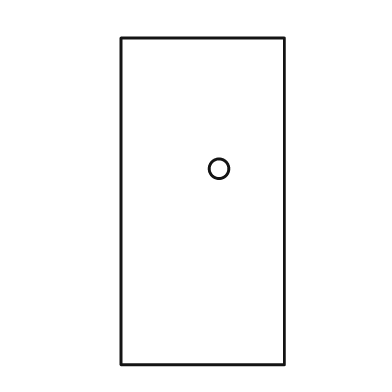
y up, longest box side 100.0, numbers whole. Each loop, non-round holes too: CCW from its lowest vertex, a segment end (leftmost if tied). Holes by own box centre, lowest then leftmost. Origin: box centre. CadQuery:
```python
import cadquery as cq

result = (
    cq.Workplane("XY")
    .moveTo(-25.0, -50.0)
    .lineTo(25.0, -50.0)
    .lineTo(25.0, 50.0)
    .lineTo(-25.0, 50.0)
    .close()
    .moveTo(5.0, 10.0)
    .circle(3.0)
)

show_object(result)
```